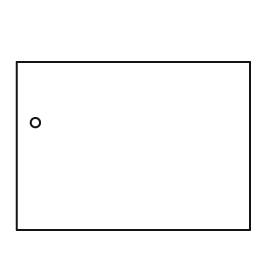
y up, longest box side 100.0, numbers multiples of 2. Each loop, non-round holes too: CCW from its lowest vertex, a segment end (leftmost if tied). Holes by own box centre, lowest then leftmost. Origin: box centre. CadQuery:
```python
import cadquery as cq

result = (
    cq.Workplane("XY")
    .moveTo(-50.0, -36.0)
    .lineTo(50.0, -36.0)
    .lineTo(50.0, 36.0)
    .lineTo(-50.0, 36.0)
    .close()
    .moveTo(-42.0, 10.0)
    .circle(2.0)
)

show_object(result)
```